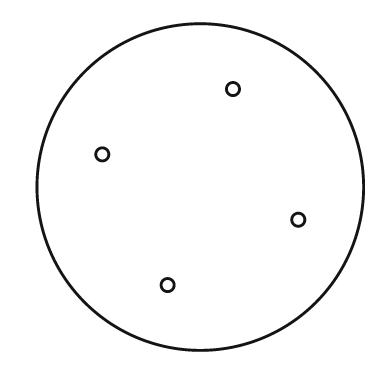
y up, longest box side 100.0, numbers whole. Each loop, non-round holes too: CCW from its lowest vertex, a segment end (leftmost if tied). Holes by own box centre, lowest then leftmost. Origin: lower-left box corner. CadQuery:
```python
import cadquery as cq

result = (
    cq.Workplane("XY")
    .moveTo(50.0, 50.0)
    .circle(50.0)
    .moveTo(40.0, 20.0)
    .circle(2.0)
    .moveTo(80.0, 40.0)
    .circle(2.0)
    .moveTo(20.0, 60.0)
    .circle(2.0)
    .moveTo(60.0, 80.0)
    .circle(2.0)
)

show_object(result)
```